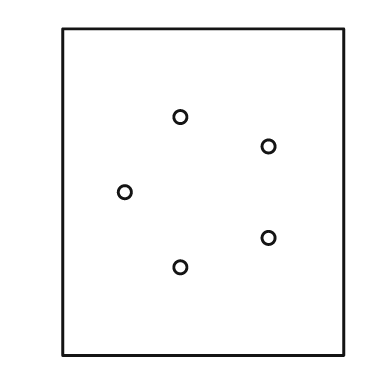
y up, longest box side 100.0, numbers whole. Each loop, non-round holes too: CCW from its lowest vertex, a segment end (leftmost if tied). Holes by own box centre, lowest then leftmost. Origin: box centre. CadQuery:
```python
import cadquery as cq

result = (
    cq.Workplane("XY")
    .moveTo(-43.0, -50.0)
    .lineTo(43.0, -50.0)
    .lineTo(43.0, 50.0)
    .lineTo(-43.0, 50.0)
    .close()
    .moveTo(-7.0, -23.0)
    .circle(2.0)
    .moveTo(20.0, -14.0)
    .circle(2.0)
    .moveTo(-24.0, 0.0)
    .circle(2.0)
    .moveTo(20.0, 14.0)
    .circle(2.0)
    .moveTo(-7.0, 23.0)
    .circle(2.0)
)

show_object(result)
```